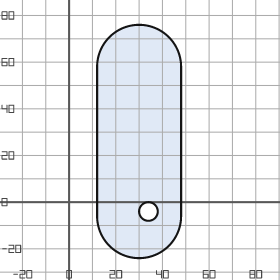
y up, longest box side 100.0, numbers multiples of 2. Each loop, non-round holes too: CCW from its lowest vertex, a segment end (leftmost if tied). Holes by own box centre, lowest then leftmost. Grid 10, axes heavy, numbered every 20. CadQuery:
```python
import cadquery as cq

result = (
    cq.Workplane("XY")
    .moveTo(12.0, -6.0)
    .threePointArc((30.0, -24.0), (48.0, -6.0))
    .lineTo(48.0, 58.0)
    .threePointArc((30.0, 76.0), (12.0, 58.0))
    .close()
    .moveTo(34.0, -4.0)
    .circle(4.0)
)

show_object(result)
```